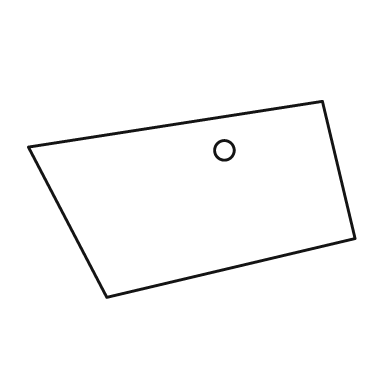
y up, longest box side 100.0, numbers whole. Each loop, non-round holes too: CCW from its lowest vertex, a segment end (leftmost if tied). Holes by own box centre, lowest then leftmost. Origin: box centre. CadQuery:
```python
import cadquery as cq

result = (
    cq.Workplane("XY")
    .moveTo(-26.0, -30.0)
    .lineTo(50.0, -12.0)
    .lineTo(40.0, 30.0)
    .lineTo(-50.0, 16.0)
    .close()
    .moveTo(10.0, 15.0)
    .circle(3.0)
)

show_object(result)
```